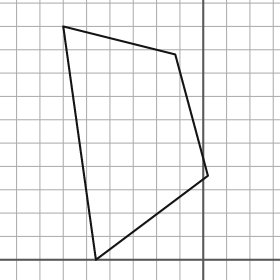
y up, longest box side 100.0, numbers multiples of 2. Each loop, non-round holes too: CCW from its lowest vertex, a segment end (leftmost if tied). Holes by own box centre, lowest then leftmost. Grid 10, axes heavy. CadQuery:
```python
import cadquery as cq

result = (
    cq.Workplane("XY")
    .moveTo(-46.0, 0.0)
    .lineTo(2.0, 36.0)
    .lineTo(-12.0, 88.0)
    .lineTo(-60.0, 100.0)
    .close()
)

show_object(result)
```